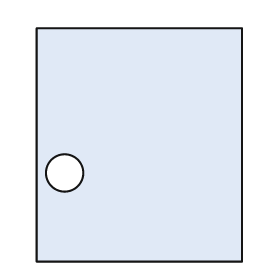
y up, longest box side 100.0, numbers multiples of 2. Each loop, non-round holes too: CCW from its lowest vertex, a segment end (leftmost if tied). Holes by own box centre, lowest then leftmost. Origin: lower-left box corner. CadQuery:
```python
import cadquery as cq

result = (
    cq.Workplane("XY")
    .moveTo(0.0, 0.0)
    .lineTo(88.0, 0.0)
    .lineTo(88.0, 100.0)
    .lineTo(0.0, 100.0)
    .close()
    .moveTo(12.0, 38.0)
    .circle(8.0)
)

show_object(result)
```